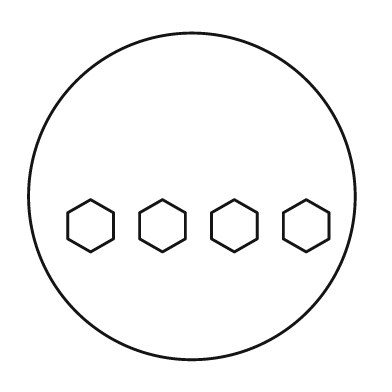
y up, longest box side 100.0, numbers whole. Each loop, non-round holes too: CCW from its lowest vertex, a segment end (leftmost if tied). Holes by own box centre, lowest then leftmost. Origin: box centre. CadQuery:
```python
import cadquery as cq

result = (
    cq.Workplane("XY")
    .moveTo(0.0, 0.0)
    .circle(50.0)
    .moveTo(-31.0, -17.0)
    .lineTo(-24.0, -13.0)
    .lineTo(-24.0, -5.0)
    .lineTo(-31.0, -1.0)
    .lineTo(-38.0, -5.0)
    .lineTo(-38.0, -13.0)
    .close()
    .moveTo(-9.0, -17.0)
    .lineTo(-2.0, -13.0)
    .lineTo(-2.0, -5.0)
    .lineTo(-9.0, -1.0)
    .lineTo(-16.0, -5.0)
    .lineTo(-16.0, -13.0)
    .close()
    .moveTo(13.0, -17.0)
    .lineTo(20.0, -13.0)
    .lineTo(20.0, -5.0)
    .lineTo(13.0, -1.0)
    .lineTo(6.0, -5.0)
    .lineTo(6.0, -13.0)
    .close()
    .moveTo(35.0, -17.0)
    .lineTo(42.0, -13.0)
    .lineTo(42.0, -5.0)
    .lineTo(35.0, -1.0)
    .lineTo(28.0, -5.0)
    .lineTo(28.0, -13.0)
    .close()
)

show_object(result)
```